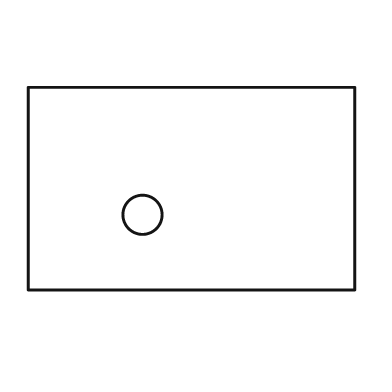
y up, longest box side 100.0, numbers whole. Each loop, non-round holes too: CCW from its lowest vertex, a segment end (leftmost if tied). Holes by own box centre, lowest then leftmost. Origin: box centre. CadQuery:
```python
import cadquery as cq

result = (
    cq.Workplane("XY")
    .moveTo(-50.0, -31.0)
    .lineTo(50.0, -31.0)
    .lineTo(50.0, 31.0)
    .lineTo(-50.0, 31.0)
    .close()
    .moveTo(-15.0, -8.0)
    .circle(6.0)
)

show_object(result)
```